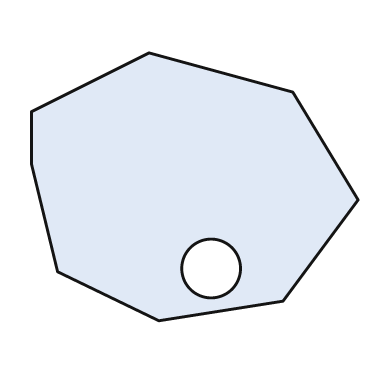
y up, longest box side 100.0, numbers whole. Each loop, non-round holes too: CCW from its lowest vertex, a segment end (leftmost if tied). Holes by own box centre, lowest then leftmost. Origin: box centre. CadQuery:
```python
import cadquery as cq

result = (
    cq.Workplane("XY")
    .moveTo(-11.0, -41.0)
    .lineTo(27.0, -35.0)
    .lineTo(50.0, -4.0)
    .lineTo(30.0, 29.0)
    .lineTo(-14.0, 41.0)
    .lineTo(-50.0, 23.0)
    .lineTo(-50.0, 7.0)
    .lineTo(-42.0, -26.0)
    .close()
    .moveTo(5.0, -25.0)
    .circle(9.0)
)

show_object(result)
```